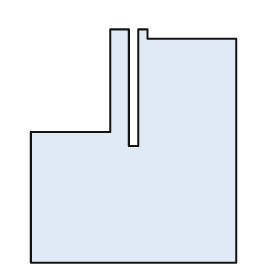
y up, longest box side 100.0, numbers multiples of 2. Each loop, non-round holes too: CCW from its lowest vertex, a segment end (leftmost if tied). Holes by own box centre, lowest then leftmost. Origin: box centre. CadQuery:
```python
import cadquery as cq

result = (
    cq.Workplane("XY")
    .moveTo(-44.0, -50.0)
    .lineTo(44.0, -50.0)
    .lineTo(44.0, 46.0)
    .lineTo(6.0, 46.0)
    .lineTo(6.0, 50.0)
    .lineTo(2.0, 50.0)
    .lineTo(2.0, 0.0)
    .lineTo(-2.0, 0.0)
    .lineTo(-2.0, 50.0)
    .lineTo(-10.0, 50.0)
    .lineTo(-10.0, 6.0)
    .lineTo(-44.0, 6.0)
    .close()
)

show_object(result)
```